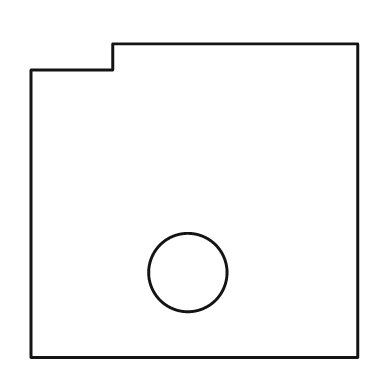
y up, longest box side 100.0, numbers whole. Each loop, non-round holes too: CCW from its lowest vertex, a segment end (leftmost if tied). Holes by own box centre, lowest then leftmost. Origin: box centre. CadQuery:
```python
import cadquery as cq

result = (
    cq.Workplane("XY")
    .moveTo(-50.0, -48.0)
    .lineTo(50.0, -48.0)
    .lineTo(50.0, 48.0)
    .lineTo(-25.0, 48.0)
    .lineTo(-25.0, 40.0)
    .lineTo(-50.0, 40.0)
    .close()
    .moveTo(-2.0, -22.0)
    .circle(12.0)
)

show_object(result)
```